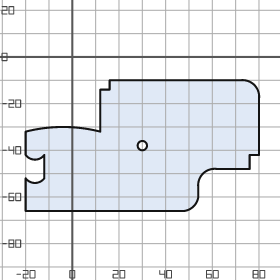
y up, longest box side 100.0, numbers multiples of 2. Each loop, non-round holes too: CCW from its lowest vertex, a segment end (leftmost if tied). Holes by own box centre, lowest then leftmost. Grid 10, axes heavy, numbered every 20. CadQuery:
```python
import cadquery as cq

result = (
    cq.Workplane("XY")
    .moveTo(-20.0, -66.0)
    .lineTo(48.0, -66.0)
    .threePointArc((52.0, -64.0), (54.0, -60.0))
    .lineTo(54.0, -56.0)
    .threePointArc((56.0, -50.0), (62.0, -48.0))
    .lineTo(76.0, -48.0)
    .lineTo(76.0, -42.0)
    .lineTo(80.0, -42.0)
    .lineTo(80.0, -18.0)
    .threePointArc((78.0, -12.0), (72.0, -10.0))
    .lineTo(16.0, -10.0)
    .lineTo(16.0, -14.0)
    .lineTo(12.0, -14.0)
    .lineTo(12.0, -32.0)
    .threePointArc((-4.0, -30.0), (-20.0, -32.0))
    .lineTo(-20.0, -42.0)
    .threePointArc((-16.0, -44.0), (-12.0, -42.0))
    .lineTo(-12.0, -52.0)
    .threePointArc((-16.0, -54.0), (-20.0, -52.0))
    .close()
    .moveTo(30.0, -38.0)
    .circle(2.0)
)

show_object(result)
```